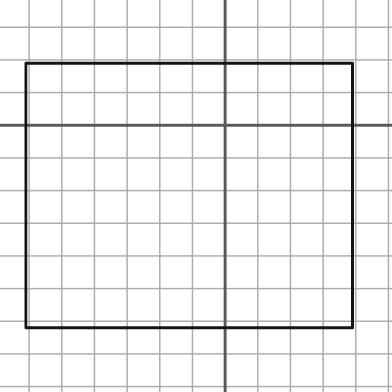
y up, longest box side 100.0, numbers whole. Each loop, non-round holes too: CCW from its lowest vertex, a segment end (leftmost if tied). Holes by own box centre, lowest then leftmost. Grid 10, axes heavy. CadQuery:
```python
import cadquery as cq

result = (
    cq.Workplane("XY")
    .moveTo(-61.0, -62.0)
    .lineTo(39.0, -62.0)
    .lineTo(39.0, 19.0)
    .lineTo(-61.0, 19.0)
    .close()
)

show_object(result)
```